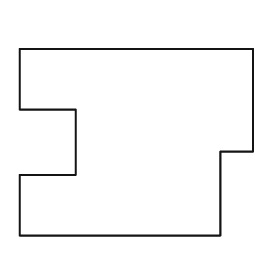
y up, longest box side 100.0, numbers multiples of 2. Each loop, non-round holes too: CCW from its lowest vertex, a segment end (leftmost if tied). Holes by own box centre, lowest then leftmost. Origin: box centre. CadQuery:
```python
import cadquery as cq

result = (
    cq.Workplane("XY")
    .moveTo(-50.0, -40.0)
    .lineTo(36.0, -40.0)
    .lineTo(36.0, -4.0)
    .lineTo(50.0, -4.0)
    .lineTo(50.0, 40.0)
    .lineTo(-50.0, 40.0)
    .lineTo(-50.0, 14.0)
    .lineTo(-26.0, 14.0)
    .lineTo(-26.0, -14.0)
    .lineTo(-50.0, -14.0)
    .close()
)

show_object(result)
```